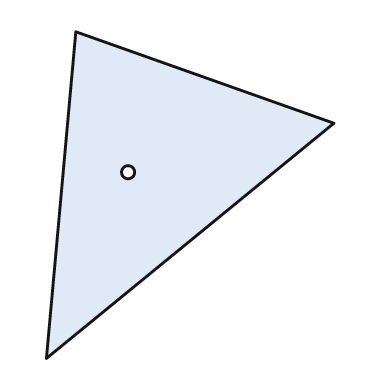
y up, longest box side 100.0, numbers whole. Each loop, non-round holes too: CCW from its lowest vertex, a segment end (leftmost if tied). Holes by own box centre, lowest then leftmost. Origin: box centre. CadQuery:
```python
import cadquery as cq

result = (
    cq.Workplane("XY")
    .moveTo(-44.0, -50.0)
    .lineTo(44.0, 22.0)
    .lineTo(-35.0, 50.0)
    .close()
    .moveTo(-19.0, 7.0)
    .circle(2.0)
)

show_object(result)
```